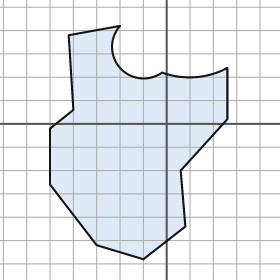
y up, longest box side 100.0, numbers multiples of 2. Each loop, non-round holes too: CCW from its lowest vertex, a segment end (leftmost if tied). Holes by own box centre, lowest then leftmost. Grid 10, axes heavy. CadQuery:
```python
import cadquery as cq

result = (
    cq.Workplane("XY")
    .moveTo(-10.0, -58.0)
    .lineTo(8.0, -44.0)
    .lineTo(6.0, -20.0)
    .lineTo(26.0, 2.0)
    .lineTo(26.0, 24.0)
    .threePointArc((12.0, 20.0), (-2.0, 22.0))
    .threePointArc((-20.0, 24.0), (-20.0, 42.0))
    .lineTo(-42.0, 38.0)
    .lineTo(-40.0, 6.0)
    .lineTo(-50.0, -2.0)
    .lineTo(-50.0, -26.0)
    .lineTo(-30.0, -52.0)
    .close()
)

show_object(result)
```